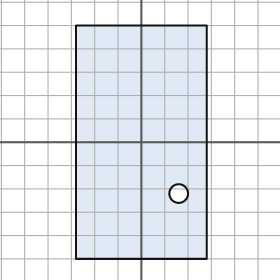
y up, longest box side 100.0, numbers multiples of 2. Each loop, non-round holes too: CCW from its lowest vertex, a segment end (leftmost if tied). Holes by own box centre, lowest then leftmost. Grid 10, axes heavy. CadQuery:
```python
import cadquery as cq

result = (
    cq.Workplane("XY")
    .moveTo(-28.0, -50.0)
    .lineTo(28.0, -50.0)
    .lineTo(28.0, 50.0)
    .lineTo(-28.0, 50.0)
    .close()
    .moveTo(16.0, -22.0)
    .circle(4.0)
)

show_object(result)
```